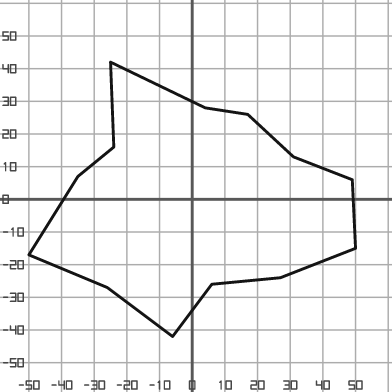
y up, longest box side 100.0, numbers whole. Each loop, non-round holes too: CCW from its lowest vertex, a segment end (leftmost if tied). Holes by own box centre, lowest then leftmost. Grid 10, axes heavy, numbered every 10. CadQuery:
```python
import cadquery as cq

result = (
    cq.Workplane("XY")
    .moveTo(-6.0, -42.0)
    .lineTo(6.0, -26.0)
    .lineTo(27.0, -24.0)
    .lineTo(50.0, -15.0)
    .lineTo(49.0, 6.0)
    .lineTo(31.0, 13.0)
    .lineTo(17.0, 26.0)
    .lineTo(4.0, 28.0)
    .lineTo(-25.0, 42.0)
    .lineTo(-24.0, 16.0)
    .lineTo(-35.0, 7.0)
    .lineTo(-50.0, -17.0)
    .lineTo(-26.0, -27.0)
    .close()
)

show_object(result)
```